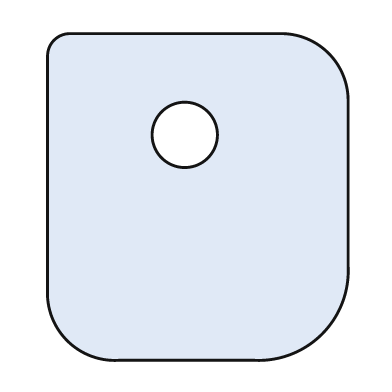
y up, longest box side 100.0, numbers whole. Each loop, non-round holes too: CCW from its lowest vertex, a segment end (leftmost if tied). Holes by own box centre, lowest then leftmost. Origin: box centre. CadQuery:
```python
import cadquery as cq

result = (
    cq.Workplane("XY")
    .moveTo(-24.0, -50.0)
    .lineTo(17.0, -50.0)
    .threePointArc((38.0, -42.0), (46.0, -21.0))
    .lineTo(46.0, 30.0)
    .threePointArc((40.0, 44.0), (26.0, 50.0))
    .lineTo(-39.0, 50.0)
    .threePointArc((-44.0, 48.0), (-46.0, 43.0))
    .lineTo(-46.0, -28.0)
    .threePointArc((-40.0, -44.0), (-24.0, -50.0))
    .close()
    .moveTo(-4.0, 19.0)
    .circle(10.0)
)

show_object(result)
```